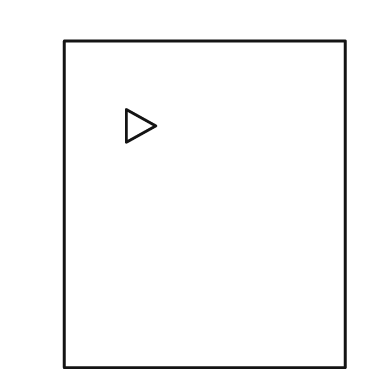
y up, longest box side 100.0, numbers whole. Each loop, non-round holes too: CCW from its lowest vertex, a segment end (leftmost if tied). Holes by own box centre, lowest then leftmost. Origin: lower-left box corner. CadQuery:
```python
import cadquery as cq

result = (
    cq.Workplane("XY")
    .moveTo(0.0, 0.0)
    .lineTo(86.0, 0.0)
    .lineTo(86.0, 100.0)
    .lineTo(0.0, 100.0)
    .close()
    .moveTo(19.0, 69.0)
    .lineTo(28.0, 74.0)
    .lineTo(19.0, 79.0)
    .close()
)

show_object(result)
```